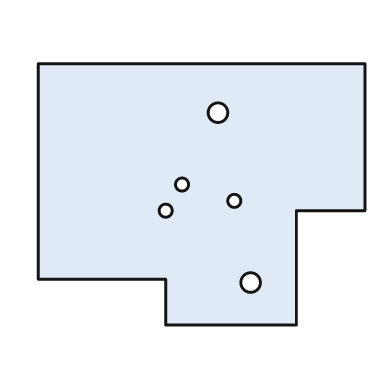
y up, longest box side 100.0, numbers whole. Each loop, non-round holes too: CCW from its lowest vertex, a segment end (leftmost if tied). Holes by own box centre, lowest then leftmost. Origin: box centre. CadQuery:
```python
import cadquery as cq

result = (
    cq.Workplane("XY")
    .moveTo(-11.0, -40.0)
    .lineTo(29.0, -40.0)
    .lineTo(29.0, -5.0)
    .lineTo(50.0, -5.0)
    .lineTo(50.0, 40.0)
    .lineTo(-50.0, 40.0)
    .lineTo(-50.0, -26.0)
    .lineTo(-11.0, -26.0)
    .close()
    .moveTo(15.0, -27.0)
    .circle(3.0)
    .moveTo(-11.0, -5.0)
    .circle(2.0)
    .moveTo(10.0, -2.0)
    .circle(2.0)
    .moveTo(-6.0, 3.0)
    .circle(2.0)
    .moveTo(5.0, 25.0)
    .circle(3.0)
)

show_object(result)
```